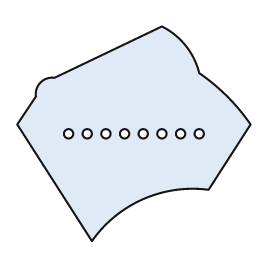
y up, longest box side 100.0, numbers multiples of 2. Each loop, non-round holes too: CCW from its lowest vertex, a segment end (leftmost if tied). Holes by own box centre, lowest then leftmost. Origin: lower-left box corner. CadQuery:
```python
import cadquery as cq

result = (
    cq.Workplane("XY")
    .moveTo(32.0, 0.0)
    .threePointArc((54.0, 18.0), (82.0, 22.0))
    .lineTo(100.0, 50.0)
    .threePointArc((90.0, 62.0), (78.0, 72.0))
    .threePointArc((72.0, 84.0), (62.0, 92.0))
    .lineTo(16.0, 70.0)
    .threePointArc((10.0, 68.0), (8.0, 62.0))
    .lineTo(0.0, 50.0)
    .close()
    .moveTo(22.0, 46.0)
    .circle(2.0)
    .moveTo(30.0, 46.0)
    .circle(2.0)
    .moveTo(38.0, 46.0)
    .circle(2.0)
    .moveTo(46.0, 46.0)
    .circle(2.0)
    .moveTo(54.0, 46.0)
    .circle(2.0)
    .moveTo(62.0, 46.0)
    .circle(2.0)
    .moveTo(70.0, 46.0)
    .circle(2.0)
    .moveTo(78.0, 46.0)
    .circle(2.0)
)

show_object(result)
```